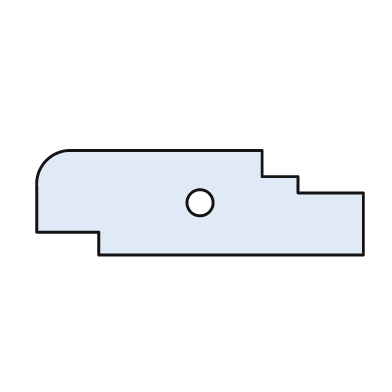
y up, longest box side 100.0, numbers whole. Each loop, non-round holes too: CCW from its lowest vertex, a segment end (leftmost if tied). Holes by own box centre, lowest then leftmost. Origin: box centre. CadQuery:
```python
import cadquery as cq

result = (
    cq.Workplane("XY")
    .moveTo(-31.0, -16.0)
    .lineTo(50.0, -16.0)
    .lineTo(50.0, 3.0)
    .lineTo(30.0, 3.0)
    .lineTo(30.0, 8.0)
    .lineTo(19.0, 8.0)
    .lineTo(19.0, 16.0)
    .lineTo(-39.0, 16.0)
    .threePointArc((-47.0, 13.0), (-50.0, 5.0))
    .lineTo(-50.0, -9.0)
    .lineTo(-31.0, -9.0)
    .close()
    .moveTo(0.0, 0.0)
    .circle(4.0)
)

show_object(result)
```